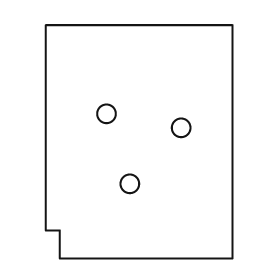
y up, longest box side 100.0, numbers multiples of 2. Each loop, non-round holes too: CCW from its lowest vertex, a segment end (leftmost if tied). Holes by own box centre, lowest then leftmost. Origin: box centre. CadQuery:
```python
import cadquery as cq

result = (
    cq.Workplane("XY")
    .moveTo(-34.0, -50.0)
    .lineTo(40.0, -50.0)
    .lineTo(40.0, 50.0)
    .lineTo(-40.0, 50.0)
    .lineTo(-40.0, -38.0)
    .lineTo(-34.0, -38.0)
    .close()
    .moveTo(-4.0, -18.0)
    .circle(4.0)
    .moveTo(18.0, 6.0)
    .circle(4.0)
    .moveTo(-14.0, 12.0)
    .circle(4.0)
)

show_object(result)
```